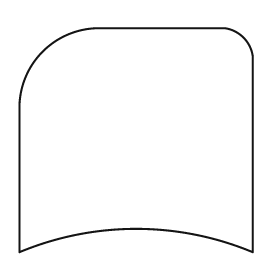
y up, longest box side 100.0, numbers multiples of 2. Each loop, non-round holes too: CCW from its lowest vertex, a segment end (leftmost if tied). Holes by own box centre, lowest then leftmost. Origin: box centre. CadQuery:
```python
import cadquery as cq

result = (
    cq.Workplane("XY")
    .moveTo(-50.0, -48.0)
    .threePointArc((0.0, -38.0), (50.0, -48.0))
    .lineTo(50.0, 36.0)
    .threePointArc((46.0, 44.0), (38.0, 48.0))
    .lineTo(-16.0, 48.0)
    .threePointArc((-40.0, 38.0), (-50.0, 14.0))
    .close()
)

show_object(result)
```